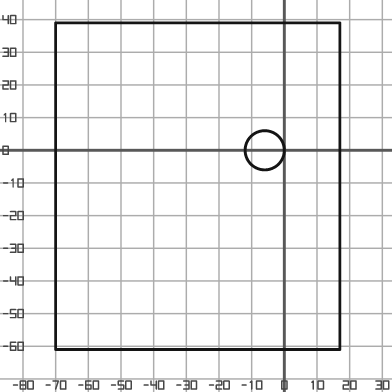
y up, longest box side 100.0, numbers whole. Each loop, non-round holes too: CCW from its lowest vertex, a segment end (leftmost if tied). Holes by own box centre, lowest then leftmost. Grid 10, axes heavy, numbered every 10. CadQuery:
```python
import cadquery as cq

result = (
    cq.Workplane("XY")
    .moveTo(-70.0, -61.0)
    .lineTo(17.0, -61.0)
    .lineTo(17.0, 39.0)
    .lineTo(-70.0, 39.0)
    .close()
    .moveTo(-6.0, 0.0)
    .circle(6.0)
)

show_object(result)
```